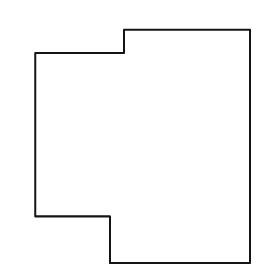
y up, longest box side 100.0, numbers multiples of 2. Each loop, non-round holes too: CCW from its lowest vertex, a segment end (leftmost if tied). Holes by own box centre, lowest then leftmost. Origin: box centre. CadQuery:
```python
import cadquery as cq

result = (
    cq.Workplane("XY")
    .moveTo(-14.0, -50.0)
    .lineTo(46.0, -50.0)
    .lineTo(46.0, 50.0)
    .lineTo(-8.0, 50.0)
    .lineTo(-8.0, 40.0)
    .lineTo(-46.0, 40.0)
    .lineTo(-46.0, -30.0)
    .lineTo(-14.0, -30.0)
    .close()
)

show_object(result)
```